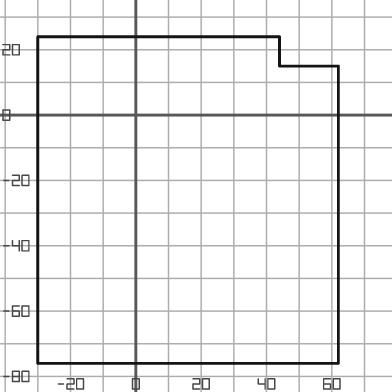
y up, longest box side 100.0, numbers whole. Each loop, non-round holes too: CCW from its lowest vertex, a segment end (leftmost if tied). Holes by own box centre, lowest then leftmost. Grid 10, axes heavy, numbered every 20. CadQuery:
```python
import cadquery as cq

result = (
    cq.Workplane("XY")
    .moveTo(-30.0, -76.0)
    .lineTo(62.0, -76.0)
    .lineTo(62.0, 15.0)
    .lineTo(44.0, 15.0)
    .lineTo(44.0, 24.0)
    .lineTo(-30.0, 24.0)
    .close()
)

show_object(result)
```